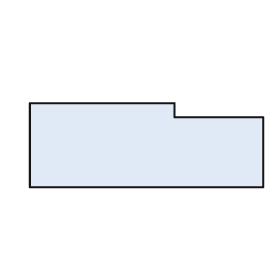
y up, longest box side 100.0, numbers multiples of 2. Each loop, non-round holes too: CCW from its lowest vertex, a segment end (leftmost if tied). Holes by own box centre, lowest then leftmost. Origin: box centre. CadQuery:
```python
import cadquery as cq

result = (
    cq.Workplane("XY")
    .moveTo(-50.0, -18.0)
    .lineTo(50.0, -18.0)
    .lineTo(50.0, 12.0)
    .lineTo(12.0, 12.0)
    .lineTo(12.0, 18.0)
    .lineTo(-50.0, 18.0)
    .close()
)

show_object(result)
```